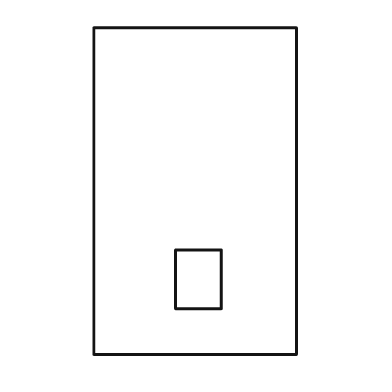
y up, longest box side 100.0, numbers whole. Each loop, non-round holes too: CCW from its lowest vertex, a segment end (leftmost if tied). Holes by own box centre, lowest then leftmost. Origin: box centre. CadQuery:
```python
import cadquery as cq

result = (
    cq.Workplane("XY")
    .moveTo(-31.0, -50.0)
    .lineTo(31.0, -50.0)
    .lineTo(31.0, 50.0)
    .lineTo(-31.0, 50.0)
    .close()
    .moveTo(-6.0, -36.0)
    .lineTo(8.0, -36.0)
    .lineTo(8.0, -18.0)
    .lineTo(-6.0, -18.0)
    .close()
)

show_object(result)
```